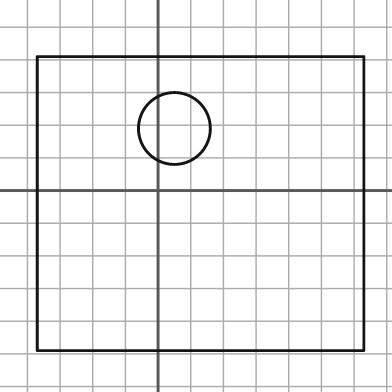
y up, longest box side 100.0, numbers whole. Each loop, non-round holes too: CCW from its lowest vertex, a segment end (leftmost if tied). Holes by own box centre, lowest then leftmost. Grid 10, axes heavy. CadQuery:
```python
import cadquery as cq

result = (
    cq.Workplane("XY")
    .moveTo(-37.0, -49.0)
    .lineTo(63.0, -49.0)
    .lineTo(63.0, 41.0)
    .lineTo(-37.0, 41.0)
    .close()
    .moveTo(5.0, 19.0)
    .circle(11.0)
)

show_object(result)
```